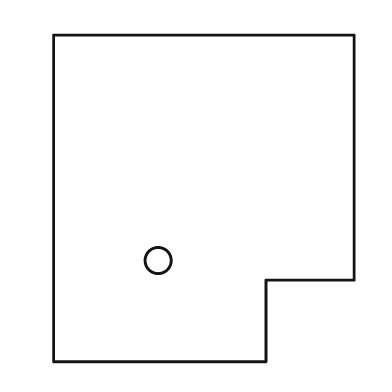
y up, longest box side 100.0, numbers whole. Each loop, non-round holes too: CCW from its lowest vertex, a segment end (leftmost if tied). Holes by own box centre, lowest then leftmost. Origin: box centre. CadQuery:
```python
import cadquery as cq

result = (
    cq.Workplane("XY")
    .moveTo(-46.0, -50.0)
    .lineTo(19.0, -50.0)
    .lineTo(19.0, -25.0)
    .lineTo(46.0, -25.0)
    .lineTo(46.0, 50.0)
    .lineTo(-46.0, 50.0)
    .close()
    .moveTo(-14.0, -19.0)
    .circle(4.0)
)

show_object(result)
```